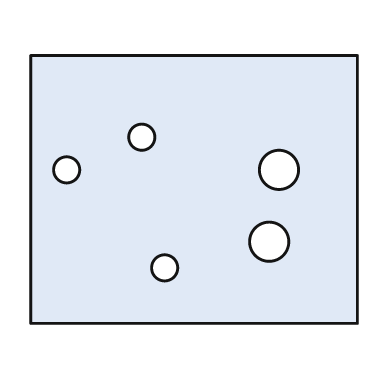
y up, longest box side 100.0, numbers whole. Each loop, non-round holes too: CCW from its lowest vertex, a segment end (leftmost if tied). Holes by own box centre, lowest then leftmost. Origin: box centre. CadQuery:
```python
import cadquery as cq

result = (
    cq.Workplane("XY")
    .moveTo(-50.0, -41.0)
    .lineTo(50.0, -41.0)
    .lineTo(50.0, 41.0)
    .lineTo(-50.0, 41.0)
    .close()
    .moveTo(-9.0, -24.0)
    .circle(4.0)
    .moveTo(23.0, -16.0)
    .circle(6.0)
    .moveTo(-39.0, 6.0)
    .circle(4.0)
    .moveTo(26.0, 6.0)
    .circle(6.0)
    .moveTo(-16.0, 16.0)
    .circle(4.0)
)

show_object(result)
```